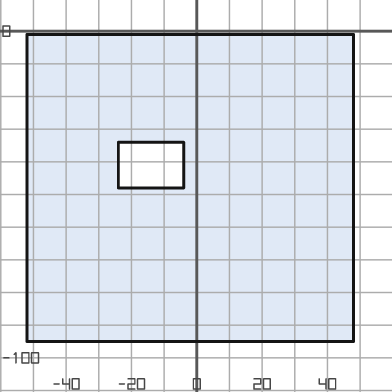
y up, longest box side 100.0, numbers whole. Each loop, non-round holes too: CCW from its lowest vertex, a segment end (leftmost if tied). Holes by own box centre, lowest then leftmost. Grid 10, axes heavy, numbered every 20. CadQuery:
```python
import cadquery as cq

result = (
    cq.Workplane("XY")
    .moveTo(-52.0, -95.0)
    .lineTo(48.0, -95.0)
    .lineTo(48.0, -1.0)
    .lineTo(-52.0, -1.0)
    .close()
    .moveTo(-24.0, -48.0)
    .lineTo(-4.0, -48.0)
    .lineTo(-4.0, -34.0)
    .lineTo(-24.0, -34.0)
    .close()
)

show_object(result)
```